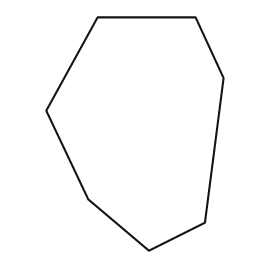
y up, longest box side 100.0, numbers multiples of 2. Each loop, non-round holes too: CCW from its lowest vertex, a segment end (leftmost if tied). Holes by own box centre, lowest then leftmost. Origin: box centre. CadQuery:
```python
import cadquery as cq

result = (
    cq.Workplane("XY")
    .moveTo(6.0, -50.0)
    .lineTo(30.0, -38.0)
    .lineTo(38.0, 24.0)
    .lineTo(26.0, 50.0)
    .lineTo(-16.0, 50.0)
    .lineTo(-38.0, 10.0)
    .lineTo(-20.0, -28.0)
    .close()
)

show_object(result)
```